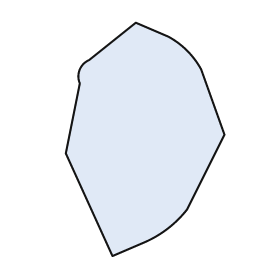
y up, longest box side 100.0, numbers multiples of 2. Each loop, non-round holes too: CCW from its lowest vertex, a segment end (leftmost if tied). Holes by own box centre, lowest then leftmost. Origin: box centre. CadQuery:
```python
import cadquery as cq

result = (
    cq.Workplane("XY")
    .moveTo(-14.0, -50.0)
    .lineTo(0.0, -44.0)
    .threePointArc((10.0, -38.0), (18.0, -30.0))
    .lineTo(34.0, 2.0)
    .lineTo(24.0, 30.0)
    .threePointArc((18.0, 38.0), (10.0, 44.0))
    .lineTo(-4.0, 50.0)
    .lineTo(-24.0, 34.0)
    .threePointArc((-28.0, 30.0), (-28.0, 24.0))
    .lineTo(-34.0, -6.0)
    .close()
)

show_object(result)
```